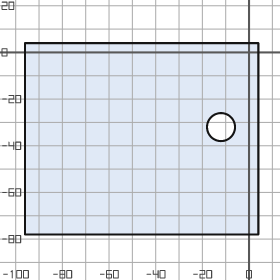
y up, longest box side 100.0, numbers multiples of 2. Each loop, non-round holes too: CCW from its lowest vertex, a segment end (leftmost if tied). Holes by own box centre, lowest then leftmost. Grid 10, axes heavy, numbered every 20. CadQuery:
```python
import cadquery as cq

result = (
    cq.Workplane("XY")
    .moveTo(-96.0, -78.0)
    .lineTo(4.0, -78.0)
    .lineTo(4.0, 4.0)
    .lineTo(-96.0, 4.0)
    .close()
    .moveTo(-12.0, -32.0)
    .circle(6.0)
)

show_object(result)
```